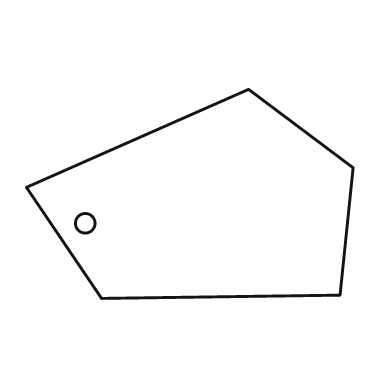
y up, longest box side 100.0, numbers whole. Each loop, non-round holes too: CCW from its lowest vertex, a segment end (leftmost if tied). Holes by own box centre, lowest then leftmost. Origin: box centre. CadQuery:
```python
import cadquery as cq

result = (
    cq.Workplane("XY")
    .moveTo(-27.0, -32.0)
    .lineTo(46.0, -31.0)
    .lineTo(50.0, 8.0)
    .lineTo(18.0, 32.0)
    .lineTo(-50.0, 2.0)
    .close()
    .moveTo(-32.0, -9.0)
    .circle(3.0)
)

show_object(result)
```